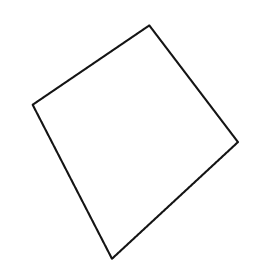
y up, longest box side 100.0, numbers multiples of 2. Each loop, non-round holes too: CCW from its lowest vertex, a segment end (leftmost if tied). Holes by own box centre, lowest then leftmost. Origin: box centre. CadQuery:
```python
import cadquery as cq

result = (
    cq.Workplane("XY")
    .moveTo(-10.0, -50.0)
    .lineTo(44.0, 0.0)
    .lineTo(6.0, 50.0)
    .lineTo(-44.0, 16.0)
    .close()
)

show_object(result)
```